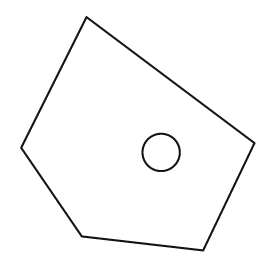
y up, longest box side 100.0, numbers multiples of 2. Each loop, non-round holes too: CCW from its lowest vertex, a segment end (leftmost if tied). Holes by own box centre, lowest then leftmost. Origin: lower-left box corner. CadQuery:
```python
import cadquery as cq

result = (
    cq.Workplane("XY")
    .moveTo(78.0, 0.0)
    .lineTo(100.0, 46.0)
    .lineTo(28.0, 100.0)
    .lineTo(0.0, 44.0)
    .lineTo(26.0, 6.0)
    .close()
    .moveTo(60.0, 42.0)
    .circle(8.0)
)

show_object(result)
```